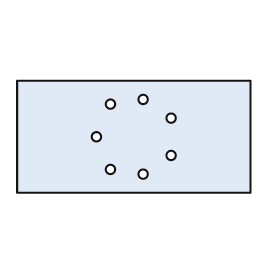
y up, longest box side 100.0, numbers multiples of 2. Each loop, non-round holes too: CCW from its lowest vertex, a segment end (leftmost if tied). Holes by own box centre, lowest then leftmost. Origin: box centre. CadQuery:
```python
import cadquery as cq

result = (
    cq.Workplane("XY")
    .moveTo(-50.0, -24.0)
    .lineTo(50.0, -24.0)
    .lineTo(50.0, 24.0)
    .lineTo(-50.0, 24.0)
    .close()
    .moveTo(4.0, -16.0)
    .circle(2.0)
    .moveTo(-10.0, -14.0)
    .circle(2.0)
    .moveTo(16.0, -8.0)
    .circle(2.0)
    .moveTo(-16.0, 0.0)
    .circle(2.0)
    .moveTo(16.0, 8.0)
    .circle(2.0)
    .moveTo(-10.0, 14.0)
    .circle(2.0)
    .moveTo(4.0, 16.0)
    .circle(2.0)
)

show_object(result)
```